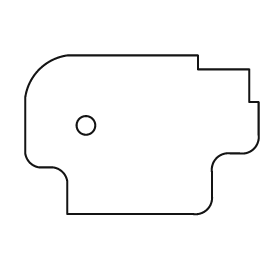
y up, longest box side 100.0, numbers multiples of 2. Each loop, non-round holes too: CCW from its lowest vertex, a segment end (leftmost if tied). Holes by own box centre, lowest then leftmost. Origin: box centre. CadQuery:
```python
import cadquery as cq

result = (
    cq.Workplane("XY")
    .moveTo(-32.0, -34.0)
    .lineTo(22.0, -34.0)
    .threePointArc((28.0, -32.0), (30.0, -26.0))
    .lineTo(30.0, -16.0)
    .threePointArc((32.0, -10.0), (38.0, -8.0))
    .lineTo(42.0, -8.0)
    .threePointArc((48.0, -6.0), (50.0, 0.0))
    .lineTo(50.0, 14.0)
    .lineTo(46.0, 14.0)
    .lineTo(46.0, 28.0)
    .lineTo(24.0, 28.0)
    .lineTo(24.0, 34.0)
    .lineTo(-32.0, 34.0)
    .threePointArc((-44.0, 28.0), (-50.0, 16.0))
    .lineTo(-50.0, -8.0)
    .threePointArc((-48.0, -12.0), (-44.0, -14.0))
    .lineTo(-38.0, -14.0)
    .threePointArc((-34.0, -16.0), (-32.0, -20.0))
    .close()
    .moveTo(-24.0, 4.0)
    .circle(4.0)
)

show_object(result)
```